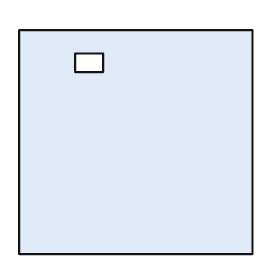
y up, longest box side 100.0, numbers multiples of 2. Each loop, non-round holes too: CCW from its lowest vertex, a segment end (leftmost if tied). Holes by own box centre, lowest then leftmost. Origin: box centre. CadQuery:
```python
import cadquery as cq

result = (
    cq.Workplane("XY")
    .moveTo(-50.0, -48.0)
    .lineTo(50.0, -48.0)
    .lineTo(50.0, 48.0)
    .lineTo(-50.0, 48.0)
    .close()
    .moveTo(-26.0, 30.0)
    .lineTo(-14.0, 30.0)
    .lineTo(-14.0, 38.0)
    .lineTo(-26.0, 38.0)
    .close()
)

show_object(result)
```